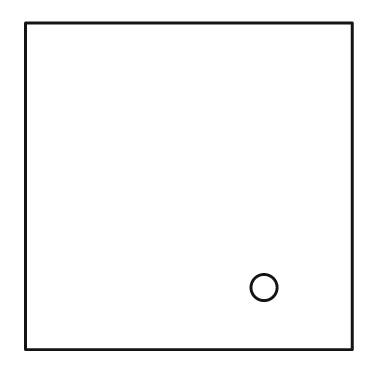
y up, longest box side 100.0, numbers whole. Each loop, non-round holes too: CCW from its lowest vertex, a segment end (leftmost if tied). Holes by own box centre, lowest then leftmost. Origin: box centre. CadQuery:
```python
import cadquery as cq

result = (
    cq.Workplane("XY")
    .moveTo(-50.0, -50.0)
    .lineTo(50.0, -50.0)
    .lineTo(50.0, 50.0)
    .lineTo(-50.0, 50.0)
    .close()
    .moveTo(23.0, -31.0)
    .circle(4.0)
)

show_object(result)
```